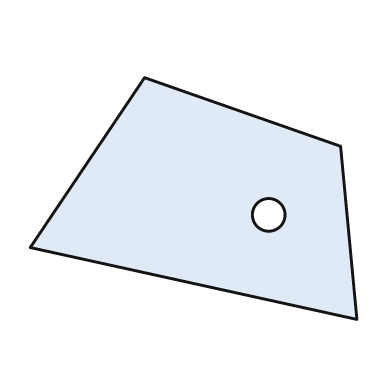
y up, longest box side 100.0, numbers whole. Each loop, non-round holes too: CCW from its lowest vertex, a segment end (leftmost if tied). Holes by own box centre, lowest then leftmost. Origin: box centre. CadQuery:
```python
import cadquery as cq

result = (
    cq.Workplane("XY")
    .moveTo(50.0, -37.0)
    .lineTo(45.0, 16.0)
    .lineTo(-15.0, 37.0)
    .lineTo(-50.0, -15.0)
    .close()
    .moveTo(23.0, -5.0)
    .circle(5.0)
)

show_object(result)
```